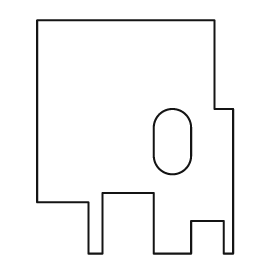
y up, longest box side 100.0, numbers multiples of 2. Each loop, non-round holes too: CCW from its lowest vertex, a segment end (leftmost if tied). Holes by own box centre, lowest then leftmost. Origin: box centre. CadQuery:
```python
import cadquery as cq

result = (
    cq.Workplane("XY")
    .moveTo(-20.0, -50.0)
    .lineTo(-14.0, -50.0)
    .lineTo(-14.0, -24.0)
    .lineTo(8.0, -24.0)
    .lineTo(8.0, -50.0)
    .lineTo(24.0, -50.0)
    .lineTo(24.0, -36.0)
    .lineTo(38.0, -36.0)
    .lineTo(38.0, -50.0)
    .lineTo(42.0, -50.0)
    .lineTo(42.0, 12.0)
    .lineTo(34.0, 12.0)
    .lineTo(34.0, 50.0)
    .lineTo(-42.0, 50.0)
    .lineTo(-42.0, -28.0)
    .lineTo(-20.0, -28.0)
    .close()
    .moveTo(8.0, -8.0)
    .threePointArc((16.0, -16.0), (24.0, -8.0))
    .lineTo(24.0, 4.0)
    .threePointArc((16.0, 12.0), (8.0, 4.0))
    .close()
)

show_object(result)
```